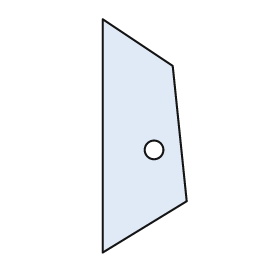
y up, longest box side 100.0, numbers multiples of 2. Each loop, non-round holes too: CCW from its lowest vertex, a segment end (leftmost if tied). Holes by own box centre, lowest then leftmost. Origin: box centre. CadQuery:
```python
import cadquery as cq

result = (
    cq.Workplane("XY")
    .moveTo(-18.0, -50.0)
    .lineTo(18.0, -28.0)
    .lineTo(12.0, 30.0)
    .lineTo(-18.0, 50.0)
    .close()
    .moveTo(4.0, -6.0)
    .circle(4.0)
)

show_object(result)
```